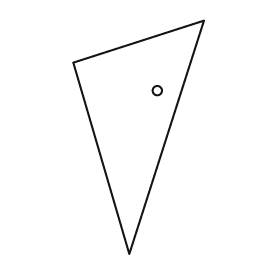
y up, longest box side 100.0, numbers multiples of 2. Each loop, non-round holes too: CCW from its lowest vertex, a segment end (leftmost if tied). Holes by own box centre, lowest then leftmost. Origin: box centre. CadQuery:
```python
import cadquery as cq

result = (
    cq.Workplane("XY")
    .moveTo(-4.0, -50.0)
    .lineTo(28.0, 50.0)
    .lineTo(-28.0, 32.0)
    .close()
    .moveTo(8.0, 20.0)
    .circle(2.0)
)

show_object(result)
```